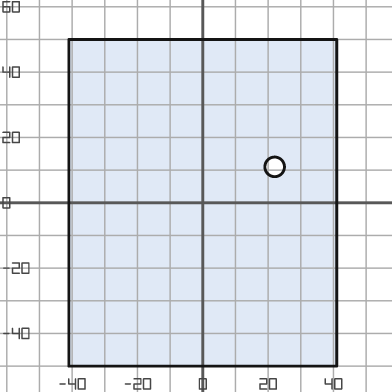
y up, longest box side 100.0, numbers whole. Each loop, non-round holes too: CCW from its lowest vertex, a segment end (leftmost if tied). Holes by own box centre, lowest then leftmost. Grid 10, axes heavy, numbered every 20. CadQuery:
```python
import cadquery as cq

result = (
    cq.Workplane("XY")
    .moveTo(-41.0, -50.0)
    .lineTo(41.0, -50.0)
    .lineTo(41.0, 50.0)
    .lineTo(-41.0, 50.0)
    .close()
    .moveTo(22.0, 11.0)
    .circle(3.0)
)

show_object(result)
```